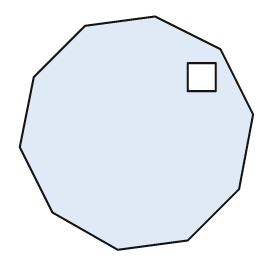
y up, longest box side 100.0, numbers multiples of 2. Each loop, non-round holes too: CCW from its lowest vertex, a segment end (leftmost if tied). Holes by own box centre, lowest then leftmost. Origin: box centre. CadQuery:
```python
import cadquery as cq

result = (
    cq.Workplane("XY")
    .moveTo(-8.0, -50.0)
    .lineTo(22.0, -46.0)
    .lineTo(44.0, -24.0)
    .lineTo(50.0, 8.0)
    .lineTo(36.0, 36.0)
    .lineTo(8.0, 50.0)
    .lineTo(-22.0, 46.0)
    .lineTo(-44.0, 24.0)
    .lineTo(-50.0, -6.0)
    .lineTo(-36.0, -34.0)
    .close()
    .moveTo(22.0, 18.0)
    .lineTo(34.0, 18.0)
    .lineTo(34.0, 30.0)
    .lineTo(22.0, 30.0)
    .close()
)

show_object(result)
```